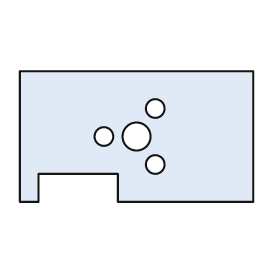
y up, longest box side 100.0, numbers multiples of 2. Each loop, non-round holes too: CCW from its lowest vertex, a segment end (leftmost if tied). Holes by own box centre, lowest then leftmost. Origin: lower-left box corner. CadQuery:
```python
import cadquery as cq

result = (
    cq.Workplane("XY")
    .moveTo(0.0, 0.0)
    .lineTo(8.0, 0.0)
    .lineTo(8.0, 12.0)
    .lineTo(42.0, 12.0)
    .lineTo(42.0, 0.0)
    .lineTo(100.0, 0.0)
    .lineTo(100.0, 56.0)
    .lineTo(0.0, 56.0)
    .close()
    .moveTo(58.0, 16.0)
    .circle(4.0)
    .moveTo(36.0, 28.0)
    .circle(4.0)
    .moveTo(50.0, 28.0)
    .circle(6.0)
    .moveTo(58.0, 40.0)
    .circle(4.0)
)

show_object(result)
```